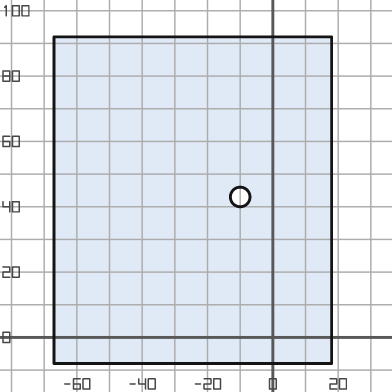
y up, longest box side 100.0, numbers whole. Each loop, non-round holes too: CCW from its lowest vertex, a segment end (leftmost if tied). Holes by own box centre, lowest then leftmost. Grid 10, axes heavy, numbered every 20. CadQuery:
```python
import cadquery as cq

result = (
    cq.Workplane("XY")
    .moveTo(-67.0, -8.0)
    .lineTo(18.0, -8.0)
    .lineTo(18.0, 92.0)
    .lineTo(-67.0, 92.0)
    .close()
    .moveTo(-10.0, 43.0)
    .circle(3.0)
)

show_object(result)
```